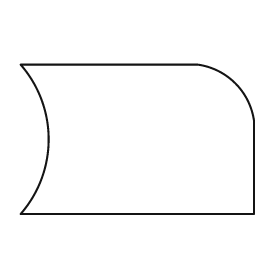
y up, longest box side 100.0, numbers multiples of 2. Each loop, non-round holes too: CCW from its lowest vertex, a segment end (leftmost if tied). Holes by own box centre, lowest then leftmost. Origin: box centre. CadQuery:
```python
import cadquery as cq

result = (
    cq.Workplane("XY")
    .moveTo(-50.0, -32.0)
    .lineTo(50.0, -32.0)
    .lineTo(50.0, 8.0)
    .threePointArc((42.0, 24.0), (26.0, 32.0))
    .lineTo(-50.0, 32.0)
    .threePointArc((-38.0, 0.0), (-50.0, -32.0))
    .close()
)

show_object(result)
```